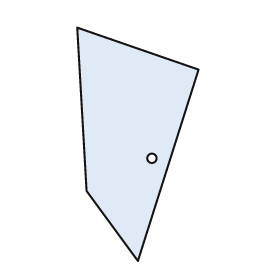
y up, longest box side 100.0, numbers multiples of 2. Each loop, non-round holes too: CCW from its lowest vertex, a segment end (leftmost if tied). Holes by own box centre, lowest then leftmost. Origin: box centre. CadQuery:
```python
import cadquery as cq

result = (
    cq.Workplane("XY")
    .moveTo(0.0, -50.0)
    .lineTo(26.0, 32.0)
    .lineTo(-26.0, 50.0)
    .lineTo(-22.0, -20.0)
    .close()
    .moveTo(6.0, -6.0)
    .circle(2.0)
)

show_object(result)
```